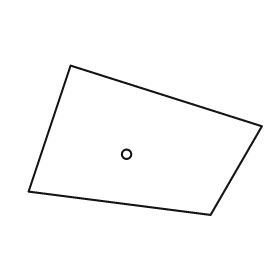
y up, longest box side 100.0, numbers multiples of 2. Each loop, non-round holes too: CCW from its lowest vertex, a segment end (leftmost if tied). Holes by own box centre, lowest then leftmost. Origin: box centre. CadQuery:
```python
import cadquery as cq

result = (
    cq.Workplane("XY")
    .moveTo(28.0, -32.0)
    .lineTo(50.0, 6.0)
    .lineTo(-32.0, 32.0)
    .lineTo(-50.0, -22.0)
    .close()
    .moveTo(-8.0, -6.0)
    .circle(2.0)
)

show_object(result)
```